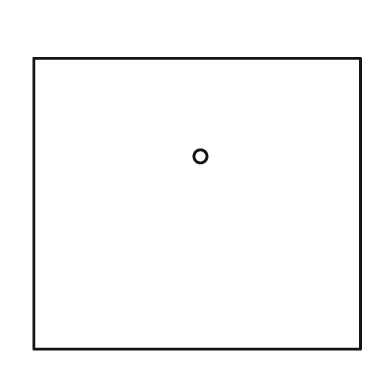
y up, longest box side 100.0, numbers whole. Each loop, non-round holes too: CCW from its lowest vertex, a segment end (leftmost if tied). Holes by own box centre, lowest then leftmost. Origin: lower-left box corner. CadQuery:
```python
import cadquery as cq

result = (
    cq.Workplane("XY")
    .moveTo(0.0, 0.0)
    .lineTo(100.0, 0.0)
    .lineTo(100.0, 89.0)
    .lineTo(0.0, 89.0)
    .close()
    .moveTo(51.0, 59.0)
    .circle(2.0)
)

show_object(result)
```